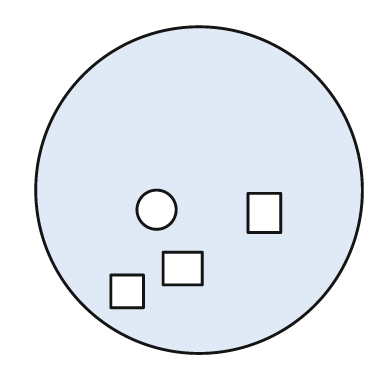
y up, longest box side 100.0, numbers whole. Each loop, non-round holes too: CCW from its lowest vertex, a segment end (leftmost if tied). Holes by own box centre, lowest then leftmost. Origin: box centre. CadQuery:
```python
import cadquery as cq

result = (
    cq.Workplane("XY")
    .moveTo(0.0, 0.0)
    .circle(50.0)
    .moveTo(-27.0, -36.0)
    .lineTo(-17.0, -36.0)
    .lineTo(-17.0, -26.0)
    .lineTo(-27.0, -26.0)
    .close()
    .moveTo(-11.0, -29.0)
    .lineTo(1.0, -29.0)
    .lineTo(1.0, -19.0)
    .lineTo(-11.0, -19.0)
    .close()
    .moveTo(15.0, -13.0)
    .lineTo(25.0, -13.0)
    .lineTo(25.0, -1.0)
    .lineTo(15.0, -1.0)
    .close()
    .moveTo(-13.0, -6.0)
    .circle(6.0)
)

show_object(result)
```